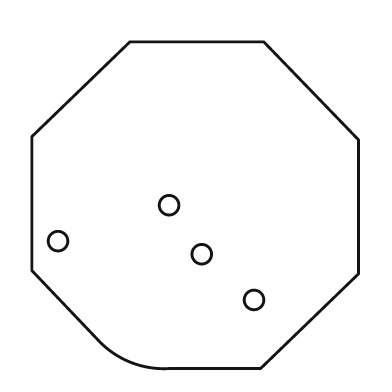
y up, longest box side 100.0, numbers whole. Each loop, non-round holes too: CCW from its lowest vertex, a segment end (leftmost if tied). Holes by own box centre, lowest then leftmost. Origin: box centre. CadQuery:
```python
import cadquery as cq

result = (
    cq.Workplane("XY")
    .moveTo(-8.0, -50.0)
    .lineTo(20.0, -50.0)
    .lineTo(50.0, -21.0)
    .lineTo(50.0, 20.0)
    .lineTo(21.0, 50.0)
    .lineTo(-20.0, 50.0)
    .lineTo(-50.0, 21.0)
    .lineTo(-50.0, -20.0)
    .lineTo(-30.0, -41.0)
    .threePointArc((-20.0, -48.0), (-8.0, -50.0))
    .close()
    .moveTo(18.0, -29.0)
    .circle(3.0)
    .moveTo(2.0, -15.0)
    .circle(3.0)
    .moveTo(-42.0, -11.0)
    .circle(3.0)
    .moveTo(-8.0, 0.0)
    .circle(3.0)
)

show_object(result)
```